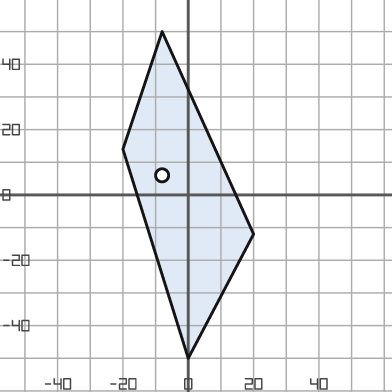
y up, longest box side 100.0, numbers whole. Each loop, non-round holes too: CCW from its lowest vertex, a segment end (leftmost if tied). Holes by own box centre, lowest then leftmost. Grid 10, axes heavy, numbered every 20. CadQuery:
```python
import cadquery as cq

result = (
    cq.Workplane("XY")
    .moveTo(0.0, -50.0)
    .lineTo(20.0, -12.0)
    .lineTo(-8.0, 50.0)
    .lineTo(-20.0, 14.0)
    .close()
    .moveTo(-8.0, 6.0)
    .circle(2.0)
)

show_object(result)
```